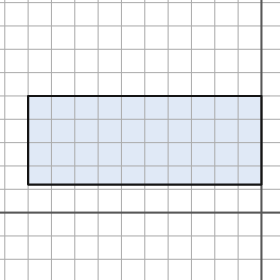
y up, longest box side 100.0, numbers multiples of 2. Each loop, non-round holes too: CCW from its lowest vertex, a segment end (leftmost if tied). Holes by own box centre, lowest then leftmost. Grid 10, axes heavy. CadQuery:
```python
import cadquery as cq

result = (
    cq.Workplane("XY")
    .moveTo(-100.0, 12.0)
    .lineTo(0.0, 12.0)
    .lineTo(0.0, 50.0)
    .lineTo(-100.0, 50.0)
    .close()
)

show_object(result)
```